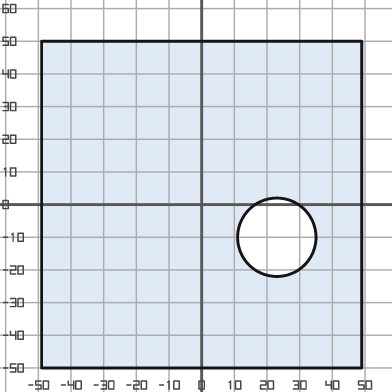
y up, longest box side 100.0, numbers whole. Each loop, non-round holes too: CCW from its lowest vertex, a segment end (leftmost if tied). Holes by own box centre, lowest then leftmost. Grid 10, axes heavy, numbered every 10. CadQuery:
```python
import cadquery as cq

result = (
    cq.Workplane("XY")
    .moveTo(-49.0, -50.0)
    .lineTo(49.0, -50.0)
    .lineTo(49.0, 50.0)
    .lineTo(-49.0, 50.0)
    .close()
    .moveTo(23.0, -10.0)
    .circle(12.0)
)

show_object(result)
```